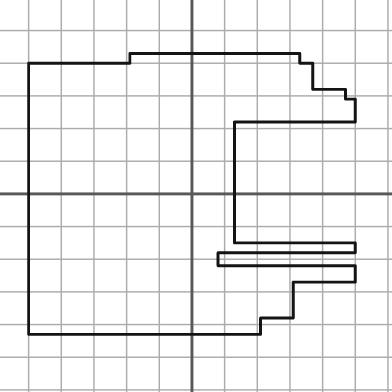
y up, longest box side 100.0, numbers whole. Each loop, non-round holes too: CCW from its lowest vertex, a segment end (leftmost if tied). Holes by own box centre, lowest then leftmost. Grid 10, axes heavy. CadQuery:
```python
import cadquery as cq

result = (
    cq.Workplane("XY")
    .moveTo(-50.0, -43.0)
    .lineTo(21.0, -43.0)
    .lineTo(21.0, -38.0)
    .lineTo(31.0, -38.0)
    .lineTo(31.0, -27.0)
    .lineTo(50.0, -27.0)
    .lineTo(50.0, -22.0)
    .lineTo(8.0, -22.0)
    .lineTo(8.0, -18.0)
    .lineTo(50.0, -18.0)
    .lineTo(50.0, -15.0)
    .lineTo(13.0, -15.0)
    .lineTo(13.0, 22.0)
    .lineTo(50.0, 22.0)
    .lineTo(50.0, 29.0)
    .lineTo(47.0, 29.0)
    .lineTo(47.0, 32.0)
    .lineTo(37.0, 32.0)
    .lineTo(37.0, 40.0)
    .lineTo(33.0, 40.0)
    .lineTo(33.0, 43.0)
    .lineTo(-19.0, 43.0)
    .lineTo(-19.0, 40.0)
    .lineTo(-50.0, 40.0)
    .close()
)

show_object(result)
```